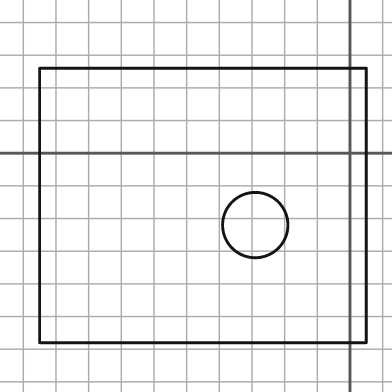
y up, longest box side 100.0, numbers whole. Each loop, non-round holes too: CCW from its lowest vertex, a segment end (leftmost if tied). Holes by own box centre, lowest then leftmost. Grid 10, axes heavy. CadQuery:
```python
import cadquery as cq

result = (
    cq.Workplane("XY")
    .moveTo(-95.0, -58.0)
    .lineTo(5.0, -58.0)
    .lineTo(5.0, 26.0)
    .lineTo(-95.0, 26.0)
    .close()
    .moveTo(-29.0, -22.0)
    .circle(10.0)
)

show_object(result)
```